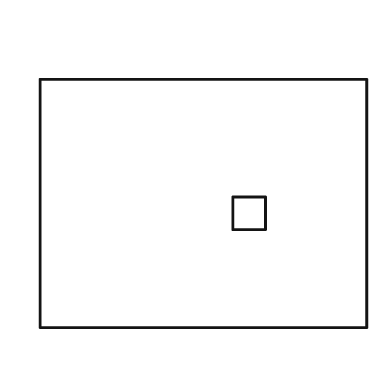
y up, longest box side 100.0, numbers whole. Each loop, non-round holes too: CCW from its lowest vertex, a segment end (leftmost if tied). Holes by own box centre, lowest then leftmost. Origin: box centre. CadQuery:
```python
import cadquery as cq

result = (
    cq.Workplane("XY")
    .moveTo(-50.0, -38.0)
    .lineTo(50.0, -38.0)
    .lineTo(50.0, 38.0)
    .lineTo(-50.0, 38.0)
    .close()
    .moveTo(9.0, -8.0)
    .lineTo(19.0, -8.0)
    .lineTo(19.0, 2.0)
    .lineTo(9.0, 2.0)
    .close()
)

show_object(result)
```